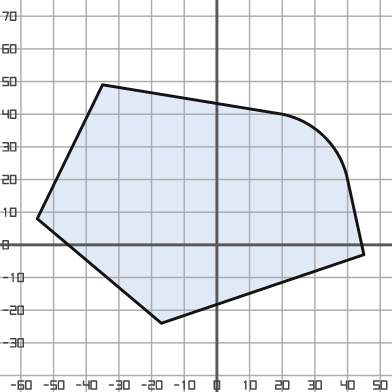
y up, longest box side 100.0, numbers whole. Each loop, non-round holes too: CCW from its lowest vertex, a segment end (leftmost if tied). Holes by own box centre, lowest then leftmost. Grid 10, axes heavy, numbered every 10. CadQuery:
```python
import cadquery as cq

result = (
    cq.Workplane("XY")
    .moveTo(-17.0, -24.0)
    .lineTo(45.0, -3.0)
    .lineTo(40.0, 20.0)
    .threePointArc((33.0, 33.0), (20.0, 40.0))
    .lineTo(-35.0, 49.0)
    .lineTo(-55.0, 8.0)
    .close()
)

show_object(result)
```